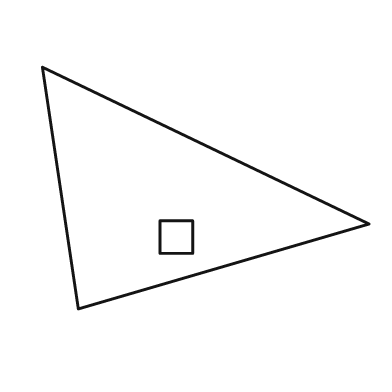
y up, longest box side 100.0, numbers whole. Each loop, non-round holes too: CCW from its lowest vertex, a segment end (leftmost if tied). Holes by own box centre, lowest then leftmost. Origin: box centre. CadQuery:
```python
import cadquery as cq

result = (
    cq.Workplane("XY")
    .moveTo(-39.0, -37.0)
    .lineTo(50.0, -11.0)
    .lineTo(-50.0, 37.0)
    .close()
    .moveTo(-14.0, -20.0)
    .lineTo(-4.0, -20.0)
    .lineTo(-4.0, -10.0)
    .lineTo(-14.0, -10.0)
    .close()
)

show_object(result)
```